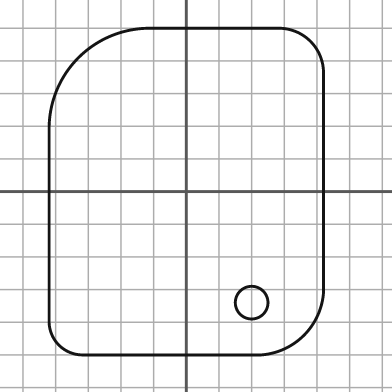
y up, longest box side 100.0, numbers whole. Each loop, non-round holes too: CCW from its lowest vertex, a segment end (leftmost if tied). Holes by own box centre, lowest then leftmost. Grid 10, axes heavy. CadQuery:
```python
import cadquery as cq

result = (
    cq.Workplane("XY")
    .moveTo(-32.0, -50.0)
    .lineTo(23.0, -50.0)
    .threePointArc((36.0, -44.0), (42.0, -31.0))
    .lineTo(42.0, 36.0)
    .threePointArc((38.0, 46.0), (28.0, 50.0))
    .lineTo(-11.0, 50.0)
    .threePointArc((-33.0, 41.0), (-42.0, 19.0))
    .lineTo(-42.0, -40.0)
    .threePointArc((-39.0, -47.0), (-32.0, -50.0))
    .close()
    .moveTo(20.0, -34.0)
    .circle(5.0)
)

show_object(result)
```